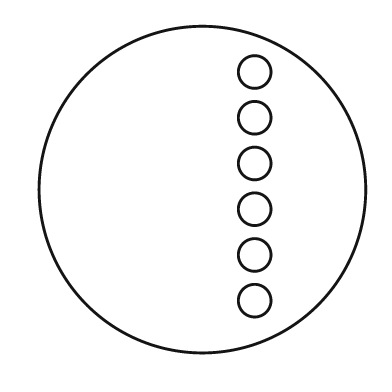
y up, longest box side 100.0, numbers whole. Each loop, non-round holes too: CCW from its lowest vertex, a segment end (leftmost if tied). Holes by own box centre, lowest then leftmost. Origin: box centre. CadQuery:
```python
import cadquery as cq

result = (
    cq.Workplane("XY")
    .moveTo(0.0, 0.0)
    .circle(50.0)
    .moveTo(16.0, -34.0)
    .circle(5.0)
    .moveTo(16.0, -20.0)
    .circle(5.0)
    .moveTo(16.0, -6.0)
    .circle(5.0)
    .moveTo(16.0, 8.0)
    .circle(5.0)
    .moveTo(16.0, 22.0)
    .circle(5.0)
    .moveTo(16.0, 36.0)
    .circle(5.0)
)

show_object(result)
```